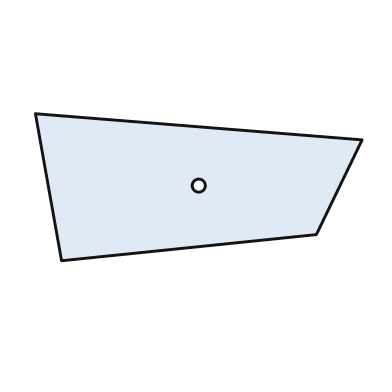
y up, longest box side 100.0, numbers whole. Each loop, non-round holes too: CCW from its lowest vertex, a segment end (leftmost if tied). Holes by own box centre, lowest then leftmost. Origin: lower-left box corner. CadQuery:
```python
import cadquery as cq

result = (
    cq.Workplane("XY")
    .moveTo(8.0, 0.0)
    .lineTo(86.0, 8.0)
    .lineTo(100.0, 37.0)
    .lineTo(0.0, 45.0)
    .close()
    .moveTo(50.0, 23.0)
    .circle(2.0)
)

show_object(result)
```